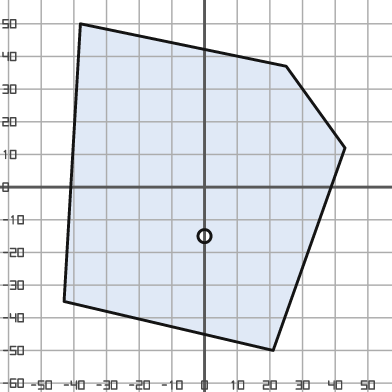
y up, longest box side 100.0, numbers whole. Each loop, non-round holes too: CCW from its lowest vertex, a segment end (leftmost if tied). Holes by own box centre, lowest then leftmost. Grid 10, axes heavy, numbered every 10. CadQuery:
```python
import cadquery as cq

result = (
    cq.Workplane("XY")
    .moveTo(21.0, -50.0)
    .lineTo(43.0, 12.0)
    .lineTo(25.0, 37.0)
    .lineTo(-38.0, 50.0)
    .lineTo(-43.0, -35.0)
    .close()
    .moveTo(0.0, -15.0)
    .circle(2.0)
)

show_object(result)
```